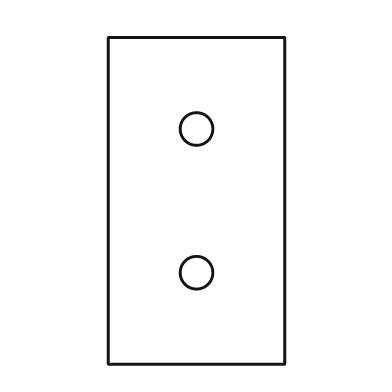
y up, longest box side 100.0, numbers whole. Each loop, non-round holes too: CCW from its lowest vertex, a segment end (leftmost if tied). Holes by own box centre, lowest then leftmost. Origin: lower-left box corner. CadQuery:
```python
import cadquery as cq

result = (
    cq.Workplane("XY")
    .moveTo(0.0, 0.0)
    .lineTo(54.0, 0.0)
    .lineTo(54.0, 100.0)
    .lineTo(0.0, 100.0)
    .close()
    .moveTo(27.0, 28.0)
    .circle(5.0)
    .moveTo(27.0, 72.0)
    .circle(5.0)
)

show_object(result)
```